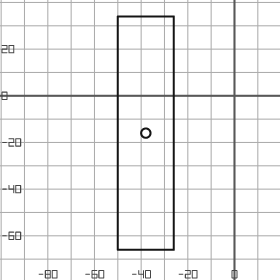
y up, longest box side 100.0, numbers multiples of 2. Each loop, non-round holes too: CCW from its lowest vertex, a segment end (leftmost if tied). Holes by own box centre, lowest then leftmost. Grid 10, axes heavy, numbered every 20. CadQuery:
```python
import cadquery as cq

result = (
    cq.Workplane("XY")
    .moveTo(-50.0, -66.0)
    .lineTo(-26.0, -66.0)
    .lineTo(-26.0, 34.0)
    .lineTo(-50.0, 34.0)
    .close()
    .moveTo(-38.0, -16.0)
    .circle(2.0)
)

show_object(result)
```